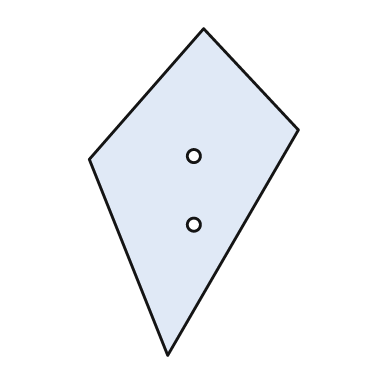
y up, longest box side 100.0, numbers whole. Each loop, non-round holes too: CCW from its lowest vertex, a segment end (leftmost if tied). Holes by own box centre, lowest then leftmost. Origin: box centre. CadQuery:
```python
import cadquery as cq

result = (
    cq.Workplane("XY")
    .moveTo(-8.0, -50.0)
    .lineTo(32.0, 19.0)
    .lineTo(3.0, 50.0)
    .lineTo(-32.0, 10.0)
    .close()
    .moveTo(0.0, -10.0)
    .circle(2.0)
    .moveTo(0.0, 11.0)
    .circle(2.0)
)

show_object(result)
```